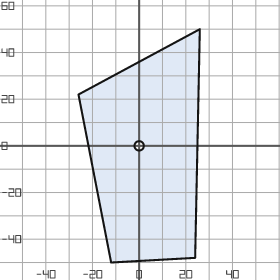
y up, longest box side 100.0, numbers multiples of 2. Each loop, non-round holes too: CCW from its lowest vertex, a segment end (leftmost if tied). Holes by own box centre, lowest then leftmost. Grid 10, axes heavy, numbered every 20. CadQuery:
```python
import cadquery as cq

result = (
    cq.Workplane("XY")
    .moveTo(-12.0, -50.0)
    .lineTo(24.0, -48.0)
    .lineTo(26.0, 50.0)
    .lineTo(-26.0, 22.0)
    .close()
    .moveTo(0.0, 0.0)
    .circle(2.0)
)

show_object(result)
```